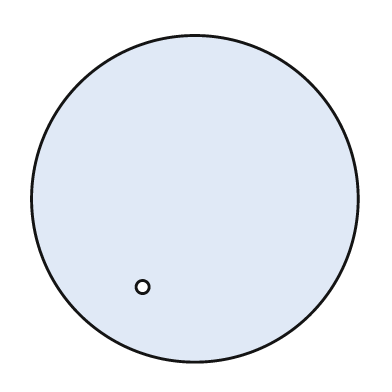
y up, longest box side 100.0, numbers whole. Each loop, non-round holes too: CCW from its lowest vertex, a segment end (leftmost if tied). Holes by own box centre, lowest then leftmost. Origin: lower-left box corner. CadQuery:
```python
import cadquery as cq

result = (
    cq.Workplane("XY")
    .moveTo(50.0, 50.0)
    .circle(50.0)
    .moveTo(34.0, 23.0)
    .circle(2.0)
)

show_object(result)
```